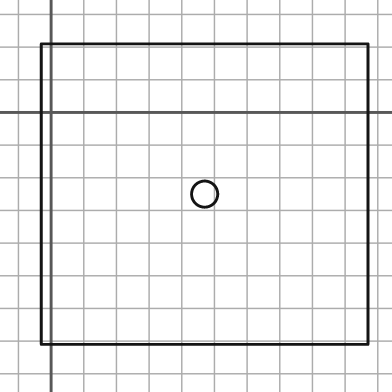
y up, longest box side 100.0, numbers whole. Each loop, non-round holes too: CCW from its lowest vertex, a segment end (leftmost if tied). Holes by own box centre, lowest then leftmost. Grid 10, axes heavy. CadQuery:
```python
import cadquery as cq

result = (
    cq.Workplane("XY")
    .moveTo(-3.0, -71.0)
    .lineTo(97.0, -71.0)
    .lineTo(97.0, 21.0)
    .lineTo(-3.0, 21.0)
    .close()
    .moveTo(47.0, -25.0)
    .circle(4.0)
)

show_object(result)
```